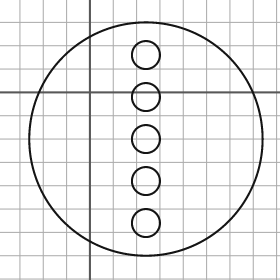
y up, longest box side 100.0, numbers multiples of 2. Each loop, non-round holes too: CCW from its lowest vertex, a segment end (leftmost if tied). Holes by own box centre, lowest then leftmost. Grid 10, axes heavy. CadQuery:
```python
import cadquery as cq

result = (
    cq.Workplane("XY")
    .moveTo(24.0, -20.0)
    .circle(50.0)
    .moveTo(24.0, -56.0)
    .circle(6.0)
    .moveTo(24.0, -38.0)
    .circle(6.0)
    .moveTo(24.0, -20.0)
    .circle(6.0)
    .moveTo(24.0, -2.0)
    .circle(6.0)
    .moveTo(24.0, 16.0)
    .circle(6.0)
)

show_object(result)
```